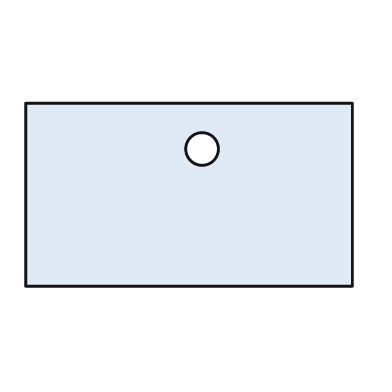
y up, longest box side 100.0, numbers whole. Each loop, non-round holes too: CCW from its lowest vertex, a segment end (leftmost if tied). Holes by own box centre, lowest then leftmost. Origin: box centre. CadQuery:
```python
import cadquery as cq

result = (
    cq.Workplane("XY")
    .moveTo(-50.0, -28.0)
    .lineTo(50.0, -28.0)
    .lineTo(50.0, 28.0)
    .lineTo(-50.0, 28.0)
    .close()
    .moveTo(4.0, 14.0)
    .circle(5.0)
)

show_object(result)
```